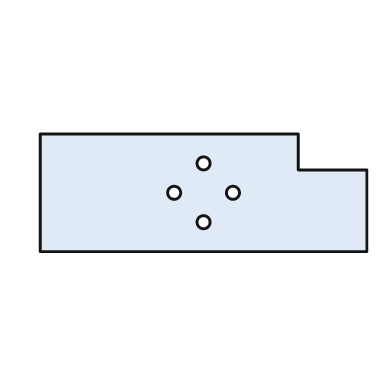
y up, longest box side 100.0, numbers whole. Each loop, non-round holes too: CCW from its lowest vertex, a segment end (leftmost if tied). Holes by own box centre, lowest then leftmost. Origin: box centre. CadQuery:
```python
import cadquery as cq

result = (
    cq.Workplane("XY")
    .moveTo(-50.0, -18.0)
    .lineTo(50.0, -18.0)
    .lineTo(50.0, 7.0)
    .lineTo(29.0, 7.0)
    .lineTo(29.0, 18.0)
    .lineTo(-50.0, 18.0)
    .close()
    .moveTo(0.0, -9.0)
    .circle(2.0)
    .moveTo(-9.0, 0.0)
    .circle(2.0)
    .moveTo(9.0, 0.0)
    .circle(2.0)
    .moveTo(0.0, 9.0)
    .circle(2.0)
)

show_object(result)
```